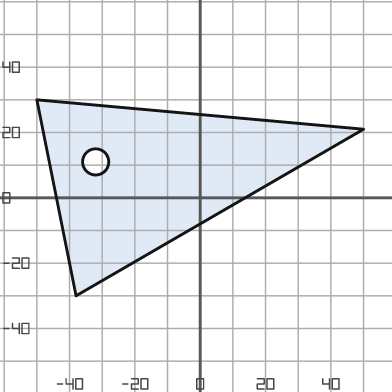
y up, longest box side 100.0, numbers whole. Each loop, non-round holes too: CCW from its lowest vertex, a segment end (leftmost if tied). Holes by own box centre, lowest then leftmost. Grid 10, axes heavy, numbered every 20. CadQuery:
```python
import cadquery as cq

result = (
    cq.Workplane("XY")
    .moveTo(-38.0, -30.0)
    .lineTo(50.0, 21.0)
    .lineTo(-50.0, 30.0)
    .close()
    .moveTo(-32.0, 11.0)
    .circle(4.0)
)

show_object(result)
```